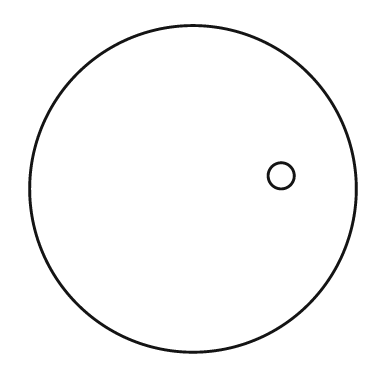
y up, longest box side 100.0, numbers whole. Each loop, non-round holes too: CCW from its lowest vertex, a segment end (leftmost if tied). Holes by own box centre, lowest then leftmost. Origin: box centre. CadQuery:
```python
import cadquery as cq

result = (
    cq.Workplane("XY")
    .moveTo(0.0, 0.0)
    .circle(50.0)
    .moveTo(27.0, 4.0)
    .circle(4.0)
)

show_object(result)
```